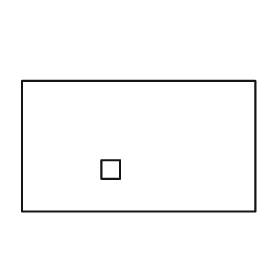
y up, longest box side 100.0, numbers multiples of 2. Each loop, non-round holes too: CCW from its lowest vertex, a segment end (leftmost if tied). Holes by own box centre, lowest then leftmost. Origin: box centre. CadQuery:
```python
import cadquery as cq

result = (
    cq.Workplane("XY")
    .moveTo(-50.0, -28.0)
    .lineTo(50.0, -28.0)
    .lineTo(50.0, 28.0)
    .lineTo(-50.0, 28.0)
    .close()
    .moveTo(-16.0, -14.0)
    .lineTo(-8.0, -14.0)
    .lineTo(-8.0, -6.0)
    .lineTo(-16.0, -6.0)
    .close()
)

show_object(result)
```